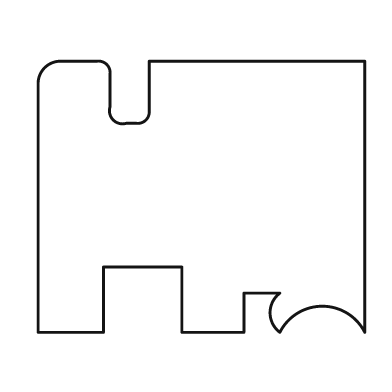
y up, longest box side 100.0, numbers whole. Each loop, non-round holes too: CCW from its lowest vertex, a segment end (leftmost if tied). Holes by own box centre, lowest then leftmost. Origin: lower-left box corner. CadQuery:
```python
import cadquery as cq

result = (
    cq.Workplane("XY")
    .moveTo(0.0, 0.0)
    .lineTo(20.0, 0.0)
    .lineTo(20.0, 20.0)
    .lineTo(44.0, 20.0)
    .lineTo(44.0, 0.0)
    .lineTo(63.0, 0.0)
    .lineTo(63.0, 12.0)
    .lineTo(74.0, 12.0)
    .threePointArc((71.0, 6.0), (74.0, 0.0))
    .threePointArc((87.0, 8.0), (100.0, 0.0))
    .lineTo(100.0, 83.0)
    .lineTo(34.0, 83.0)
    .lineTo(34.0, 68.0)
    .threePointArc((33.0, 65.0), (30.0, 64.0))
    .lineTo(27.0, 64.0)
    .threePointArc((23.0, 65.0), (22.0, 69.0))
    .lineTo(22.0, 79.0)
    .threePointArc((21.0, 82.0), (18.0, 83.0))
    .lineTo(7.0, 83.0)
    .threePointArc((2.0, 81.0), (0.0, 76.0))
    .close()
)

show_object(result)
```